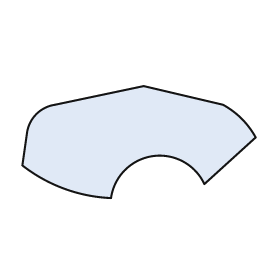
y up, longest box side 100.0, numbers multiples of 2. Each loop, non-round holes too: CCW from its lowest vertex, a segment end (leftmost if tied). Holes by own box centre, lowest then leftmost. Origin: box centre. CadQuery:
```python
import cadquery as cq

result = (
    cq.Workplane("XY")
    .moveTo(-12.0, -24.0)
    .threePointArc((6.0, -6.0), (28.0, -18.0))
    .lineTo(50.0, 2.0)
    .threePointArc((44.0, 10.0), (36.0, 16.0))
    .lineTo(2.0, 24.0)
    .lineTo(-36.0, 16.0)
    .threePointArc((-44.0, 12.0), (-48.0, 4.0))
    .lineTo(-50.0, -10.0)
    .threePointArc((-32.0, -20.0), (-12.0, -24.0))
    .close()
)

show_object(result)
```